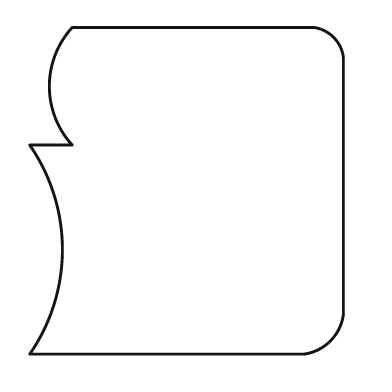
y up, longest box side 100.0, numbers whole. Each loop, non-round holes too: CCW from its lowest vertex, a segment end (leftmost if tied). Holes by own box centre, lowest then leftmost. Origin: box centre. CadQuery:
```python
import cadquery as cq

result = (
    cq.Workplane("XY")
    .moveTo(-48.0, -50.0)
    .lineTo(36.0, -50.0)
    .threePointArc((44.0, -46.0), (48.0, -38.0))
    .lineTo(48.0, 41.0)
    .threePointArc((45.0, 47.0), (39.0, 50.0))
    .lineTo(-35.0, 50.0)
    .threePointArc((-42.0, 32.0), (-35.0, 14.0))
    .lineTo(-48.0, 14.0)
    .threePointArc((-38.0, -18.0), (-48.0, -50.0))
    .close()
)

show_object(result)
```